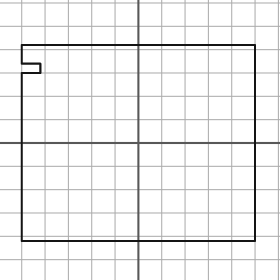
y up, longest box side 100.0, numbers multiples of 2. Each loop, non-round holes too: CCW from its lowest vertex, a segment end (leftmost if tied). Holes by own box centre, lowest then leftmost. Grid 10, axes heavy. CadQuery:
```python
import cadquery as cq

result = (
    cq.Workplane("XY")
    .moveTo(-50.0, -42.0)
    .lineTo(50.0, -42.0)
    .lineTo(50.0, 42.0)
    .lineTo(-50.0, 42.0)
    .lineTo(-50.0, 34.0)
    .lineTo(-42.0, 34.0)
    .lineTo(-42.0, 30.0)
    .lineTo(-50.0, 30.0)
    .close()
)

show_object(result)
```